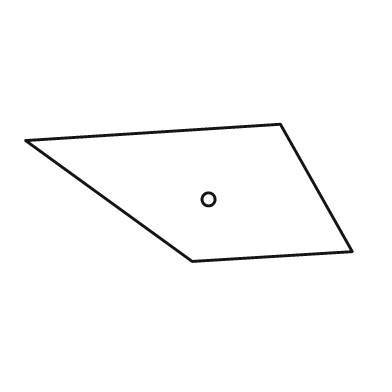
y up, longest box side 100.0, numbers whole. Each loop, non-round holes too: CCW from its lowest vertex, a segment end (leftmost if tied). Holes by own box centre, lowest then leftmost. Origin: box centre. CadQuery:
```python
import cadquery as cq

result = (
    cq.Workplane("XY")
    .moveTo(1.0, -21.0)
    .lineTo(50.0, -18.0)
    .lineTo(28.0, 21.0)
    .lineTo(-50.0, 16.0)
    .close()
    .moveTo(6.0, -2.0)
    .circle(2.0)
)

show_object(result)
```